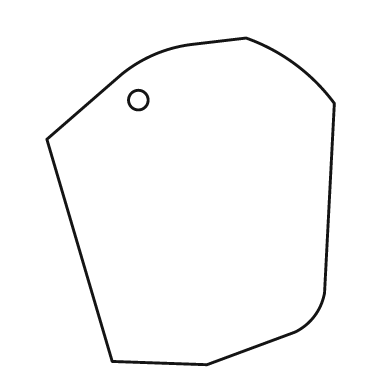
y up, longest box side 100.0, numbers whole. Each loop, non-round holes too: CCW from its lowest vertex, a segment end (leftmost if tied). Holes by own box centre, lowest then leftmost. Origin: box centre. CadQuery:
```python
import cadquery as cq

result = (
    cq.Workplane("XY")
    .moveTo(5.0, -50.0)
    .lineTo(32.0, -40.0)
    .threePointArc((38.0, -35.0), (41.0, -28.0))
    .lineTo(44.0, 30.0)
    .threePointArc((32.0, 42.0), (17.0, 50.0))
    .lineTo(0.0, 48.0)
    .threePointArc((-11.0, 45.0), (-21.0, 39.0))
    .lineTo(-44.0, 19.0)
    .lineTo(-24.0, -49.0)
    .close()
    .moveTo(-16.0, 31.0)
    .circle(3.0)
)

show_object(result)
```